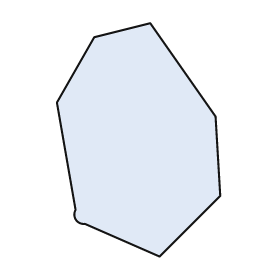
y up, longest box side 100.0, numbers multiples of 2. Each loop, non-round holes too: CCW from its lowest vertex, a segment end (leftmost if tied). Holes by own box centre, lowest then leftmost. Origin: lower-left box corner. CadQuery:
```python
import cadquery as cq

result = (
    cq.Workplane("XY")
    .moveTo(44.0, 0.0)
    .lineTo(70.0, 26.0)
    .lineTo(68.0, 60.0)
    .lineTo(40.0, 100.0)
    .lineTo(16.0, 94.0)
    .lineTo(0.0, 66.0)
    .lineTo(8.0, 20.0)
    .threePointArc((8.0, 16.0), (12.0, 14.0))
    .close()
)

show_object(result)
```